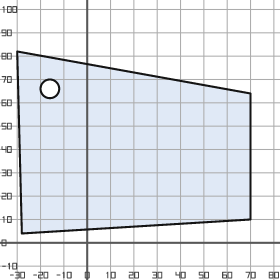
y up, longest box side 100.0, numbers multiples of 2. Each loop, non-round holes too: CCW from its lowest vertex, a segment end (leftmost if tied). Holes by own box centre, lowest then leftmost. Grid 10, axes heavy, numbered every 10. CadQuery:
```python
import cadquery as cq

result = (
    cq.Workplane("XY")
    .moveTo(-28.0, 4.0)
    .lineTo(70.0, 10.0)
    .lineTo(70.0, 64.0)
    .lineTo(-30.0, 82.0)
    .close()
    .moveTo(-16.0, 66.0)
    .circle(4.0)
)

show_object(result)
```